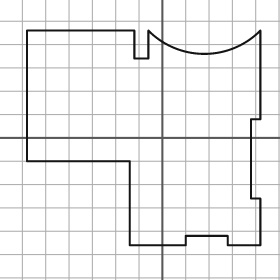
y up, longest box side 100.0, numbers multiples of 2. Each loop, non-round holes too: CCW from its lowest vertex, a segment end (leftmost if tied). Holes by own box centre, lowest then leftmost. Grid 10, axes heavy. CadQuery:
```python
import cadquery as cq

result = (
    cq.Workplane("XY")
    .moveTo(-14.0, -46.0)
    .lineTo(10.0, -46.0)
    .lineTo(10.0, -42.0)
    .lineTo(28.0, -42.0)
    .lineTo(28.0, -46.0)
    .lineTo(42.0, -46.0)
    .lineTo(42.0, -26.0)
    .lineTo(38.0, -26.0)
    .lineTo(38.0, 8.0)
    .lineTo(42.0, 8.0)
    .lineTo(42.0, 46.0)
    .threePointArc((18.0, 36.0), (-6.0, 46.0))
    .lineTo(-6.0, 34.0)
    .lineTo(-12.0, 34.0)
    .lineTo(-12.0, 46.0)
    .lineTo(-58.0, 46.0)
    .lineTo(-58.0, -10.0)
    .lineTo(-14.0, -10.0)
    .close()
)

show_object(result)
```